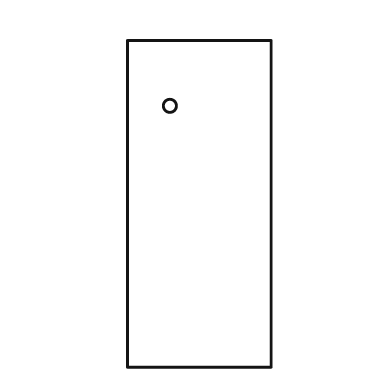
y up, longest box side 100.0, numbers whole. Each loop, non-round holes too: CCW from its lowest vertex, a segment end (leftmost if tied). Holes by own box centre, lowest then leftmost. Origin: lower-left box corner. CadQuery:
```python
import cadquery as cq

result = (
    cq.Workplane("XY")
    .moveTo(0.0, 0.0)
    .lineTo(44.0, 0.0)
    .lineTo(44.0, 100.0)
    .lineTo(0.0, 100.0)
    .close()
    .moveTo(13.0, 80.0)
    .circle(2.0)
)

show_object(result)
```